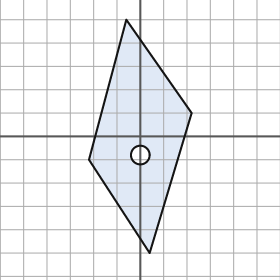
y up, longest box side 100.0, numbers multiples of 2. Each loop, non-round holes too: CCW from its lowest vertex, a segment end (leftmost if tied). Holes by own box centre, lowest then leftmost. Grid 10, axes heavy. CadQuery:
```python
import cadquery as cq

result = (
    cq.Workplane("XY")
    .moveTo(4.0, -50.0)
    .lineTo(22.0, 10.0)
    .lineTo(-6.0, 50.0)
    .lineTo(-22.0, -10.0)
    .close()
    .moveTo(0.0, -8.0)
    .circle(4.0)
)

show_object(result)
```